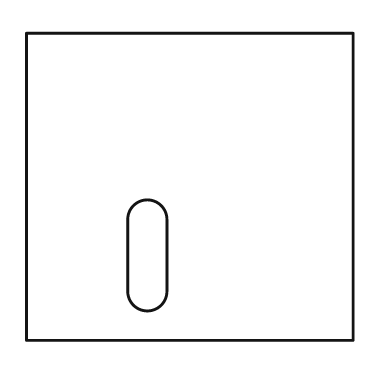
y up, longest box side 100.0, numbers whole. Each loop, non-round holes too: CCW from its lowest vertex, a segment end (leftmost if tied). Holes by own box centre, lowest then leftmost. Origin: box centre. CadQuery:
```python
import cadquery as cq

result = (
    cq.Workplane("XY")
    .moveTo(-50.0, -47.0)
    .lineTo(50.0, -47.0)
    .lineTo(50.0, 47.0)
    .lineTo(-50.0, 47.0)
    .close()
    .moveTo(-19.0, -32.0)
    .threePointArc((-13.0, -38.0), (-7.0, -32.0))
    .lineTo(-7.0, -10.0)
    .threePointArc((-13.0, -4.0), (-19.0, -10.0))
    .close()
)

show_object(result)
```